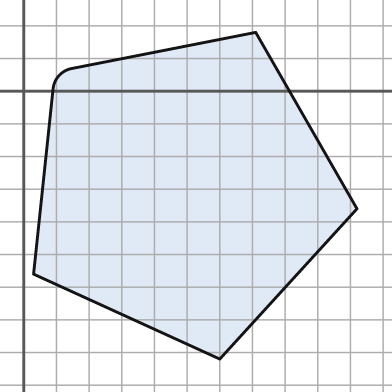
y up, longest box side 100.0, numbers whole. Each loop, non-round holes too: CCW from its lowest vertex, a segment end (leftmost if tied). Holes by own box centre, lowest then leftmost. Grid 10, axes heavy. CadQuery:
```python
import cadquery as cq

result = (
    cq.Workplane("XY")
    .moveTo(60.0, -82.0)
    .lineTo(102.0, -36.0)
    .lineTo(71.0, 18.0)
    .lineTo(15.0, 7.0)
    .threePointArc((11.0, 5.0), (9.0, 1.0))
    .lineTo(3.0, -56.0)
    .close()
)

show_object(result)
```